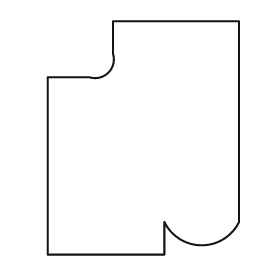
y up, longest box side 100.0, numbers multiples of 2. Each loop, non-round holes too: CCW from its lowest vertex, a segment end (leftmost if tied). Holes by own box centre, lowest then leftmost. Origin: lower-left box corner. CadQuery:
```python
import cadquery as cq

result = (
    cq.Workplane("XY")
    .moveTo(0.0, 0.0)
    .lineTo(50.0, 0.0)
    .lineTo(50.0, 14.0)
    .threePointArc((66.0, 4.0), (82.0, 14.0))
    .lineTo(82.0, 100.0)
    .lineTo(28.0, 100.0)
    .lineTo(28.0, 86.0)
    .threePointArc((26.0, 78.0), (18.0, 76.0))
    .lineTo(0.0, 76.0)
    .close()
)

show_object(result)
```